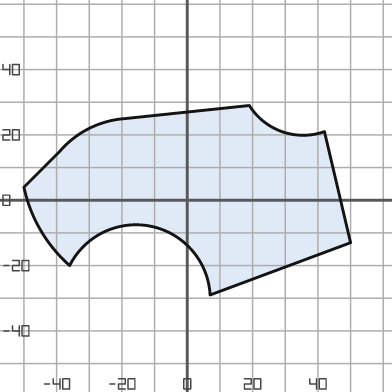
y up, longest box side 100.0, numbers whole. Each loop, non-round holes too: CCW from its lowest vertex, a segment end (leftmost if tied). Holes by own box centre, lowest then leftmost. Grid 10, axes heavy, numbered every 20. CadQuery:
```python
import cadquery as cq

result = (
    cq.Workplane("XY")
    .moveTo(7.0, -29.0)
    .lineTo(50.0, -13.0)
    .lineTo(42.0, 21.0)
    .threePointArc((29.0, 21.0), (19.0, 29.0))
    .lineTo(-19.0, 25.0)
    .threePointArc((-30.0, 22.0), (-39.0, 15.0))
    .lineTo(-50.0, 4.0)
    .threePointArc((-45.0, -9.0), (-36.0, -20.0))
    .threePointArc((-11.0, -8.0), (7.0, -29.0))
    .close()
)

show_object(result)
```